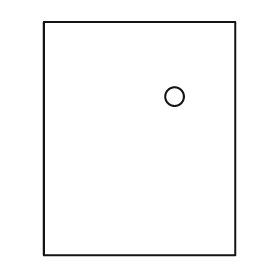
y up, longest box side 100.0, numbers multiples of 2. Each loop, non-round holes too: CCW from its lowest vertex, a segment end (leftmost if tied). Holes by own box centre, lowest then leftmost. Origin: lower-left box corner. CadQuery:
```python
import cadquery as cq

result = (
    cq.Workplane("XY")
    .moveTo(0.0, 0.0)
    .lineTo(82.0, 0.0)
    .lineTo(82.0, 100.0)
    .lineTo(0.0, 100.0)
    .close()
    .moveTo(56.0, 68.0)
    .circle(4.0)
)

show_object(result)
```